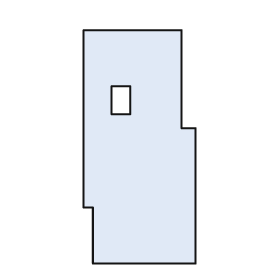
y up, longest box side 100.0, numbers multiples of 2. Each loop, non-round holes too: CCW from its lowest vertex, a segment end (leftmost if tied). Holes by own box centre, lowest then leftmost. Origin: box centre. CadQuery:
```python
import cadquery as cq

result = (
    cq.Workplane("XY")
    .moveTo(-20.0, -50.0)
    .lineTo(24.0, -50.0)
    .lineTo(24.0, 8.0)
    .lineTo(18.0, 8.0)
    .lineTo(18.0, 50.0)
    .lineTo(-24.0, 50.0)
    .lineTo(-24.0, -26.0)
    .lineTo(-20.0, -26.0)
    .close()
    .moveTo(-12.0, 14.0)
    .lineTo(-4.0, 14.0)
    .lineTo(-4.0, 26.0)
    .lineTo(-12.0, 26.0)
    .close()
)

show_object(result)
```